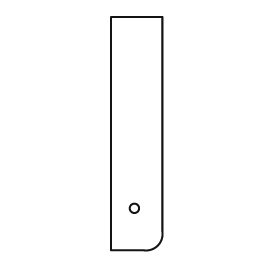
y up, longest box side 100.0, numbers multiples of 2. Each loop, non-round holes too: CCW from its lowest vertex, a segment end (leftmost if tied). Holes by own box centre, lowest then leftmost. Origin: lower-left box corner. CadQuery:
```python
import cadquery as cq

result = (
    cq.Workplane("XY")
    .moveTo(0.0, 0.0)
    .lineTo(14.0, 0.0)
    .threePointArc((20.0, 2.0), (22.0, 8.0))
    .lineTo(22.0, 100.0)
    .lineTo(0.0, 100.0)
    .close()
    .moveTo(10.0, 18.0)
    .circle(2.0)
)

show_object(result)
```